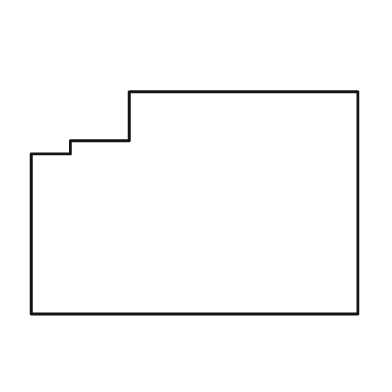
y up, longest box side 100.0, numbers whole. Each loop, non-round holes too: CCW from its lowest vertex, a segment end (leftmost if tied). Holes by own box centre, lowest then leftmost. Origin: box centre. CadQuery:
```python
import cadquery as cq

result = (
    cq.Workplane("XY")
    .moveTo(-50.0, -34.0)
    .lineTo(50.0, -34.0)
    .lineTo(50.0, 34.0)
    .lineTo(-20.0, 34.0)
    .lineTo(-20.0, 19.0)
    .lineTo(-38.0, 19.0)
    .lineTo(-38.0, 15.0)
    .lineTo(-50.0, 15.0)
    .close()
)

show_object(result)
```